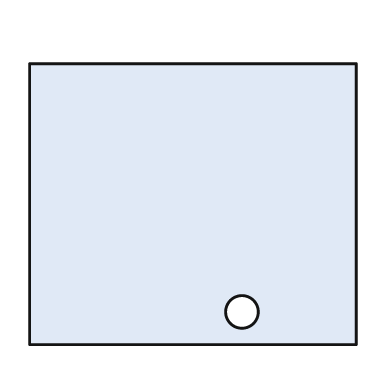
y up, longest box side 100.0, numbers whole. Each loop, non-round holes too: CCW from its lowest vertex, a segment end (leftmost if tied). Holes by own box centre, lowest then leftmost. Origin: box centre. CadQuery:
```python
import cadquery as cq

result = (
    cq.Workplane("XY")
    .moveTo(-50.0, -43.0)
    .lineTo(50.0, -43.0)
    .lineTo(50.0, 43.0)
    .lineTo(-50.0, 43.0)
    .close()
    .moveTo(15.0, -33.0)
    .circle(5.0)
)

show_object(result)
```